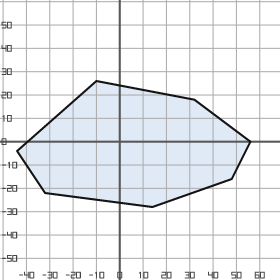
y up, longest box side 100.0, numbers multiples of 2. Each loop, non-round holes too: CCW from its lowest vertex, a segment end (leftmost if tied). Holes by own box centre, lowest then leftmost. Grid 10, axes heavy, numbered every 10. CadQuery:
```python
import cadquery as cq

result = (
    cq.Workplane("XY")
    .moveTo(14.0, -28.0)
    .lineTo(48.0, -16.0)
    .lineTo(56.0, 0.0)
    .lineTo(32.0, 18.0)
    .lineTo(-10.0, 26.0)
    .lineTo(-44.0, -4.0)
    .lineTo(-32.0, -22.0)
    .close()
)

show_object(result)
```